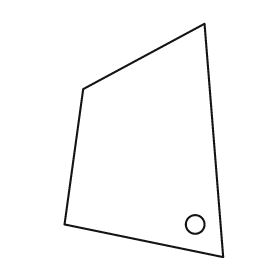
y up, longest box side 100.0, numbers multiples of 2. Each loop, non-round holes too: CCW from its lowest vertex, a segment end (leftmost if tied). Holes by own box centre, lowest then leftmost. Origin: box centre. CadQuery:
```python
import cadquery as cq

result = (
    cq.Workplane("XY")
    .moveTo(34.0, -50.0)
    .lineTo(26.0, 50.0)
    .lineTo(-26.0, 22.0)
    .lineTo(-34.0, -36.0)
    .close()
    .moveTo(22.0, -36.0)
    .circle(4.0)
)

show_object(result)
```